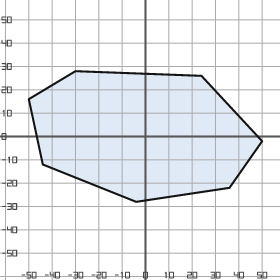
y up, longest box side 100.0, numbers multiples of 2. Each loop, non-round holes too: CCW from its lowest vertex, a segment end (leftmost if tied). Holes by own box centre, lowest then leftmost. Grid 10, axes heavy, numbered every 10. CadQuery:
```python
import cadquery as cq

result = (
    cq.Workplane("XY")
    .moveTo(-4.0, -28.0)
    .lineTo(36.0, -22.0)
    .lineTo(50.0, -2.0)
    .lineTo(24.0, 26.0)
    .lineTo(-30.0, 28.0)
    .lineTo(-50.0, 16.0)
    .lineTo(-44.0, -12.0)
    .close()
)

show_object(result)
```